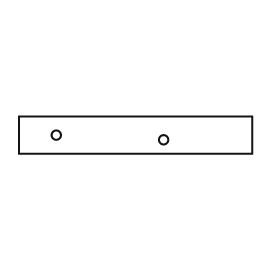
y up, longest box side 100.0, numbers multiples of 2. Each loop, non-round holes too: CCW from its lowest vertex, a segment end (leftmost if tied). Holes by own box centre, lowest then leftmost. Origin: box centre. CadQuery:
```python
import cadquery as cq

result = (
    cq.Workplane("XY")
    .moveTo(-50.0, -8.0)
    .lineTo(50.0, -8.0)
    .lineTo(50.0, 8.0)
    .lineTo(-50.0, 8.0)
    .close()
    .moveTo(12.0, -2.0)
    .circle(2.0)
    .moveTo(-34.0, 0.0)
    .circle(2.0)
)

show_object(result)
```